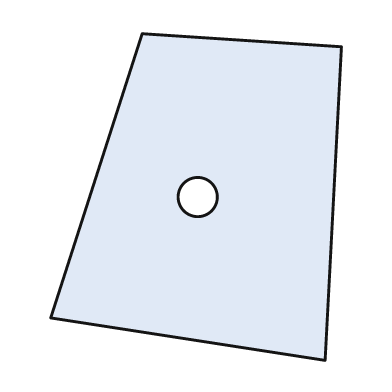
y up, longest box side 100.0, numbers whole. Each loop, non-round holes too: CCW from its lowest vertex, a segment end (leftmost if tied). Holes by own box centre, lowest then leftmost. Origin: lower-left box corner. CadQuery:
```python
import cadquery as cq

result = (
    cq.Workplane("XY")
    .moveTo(84.0, 0.0)
    .lineTo(89.0, 96.0)
    .lineTo(28.0, 100.0)
    .lineTo(0.0, 13.0)
    .close()
    .moveTo(45.0, 50.0)
    .circle(6.0)
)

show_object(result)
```